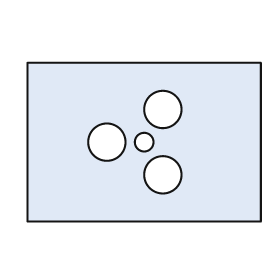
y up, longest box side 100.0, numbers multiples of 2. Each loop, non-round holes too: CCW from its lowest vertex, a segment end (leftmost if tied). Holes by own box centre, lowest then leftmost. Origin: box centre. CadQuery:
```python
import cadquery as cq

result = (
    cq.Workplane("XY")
    .moveTo(-50.0, -34.0)
    .lineTo(50.0, -34.0)
    .lineTo(50.0, 34.0)
    .lineTo(-50.0, 34.0)
    .close()
    .moveTo(8.0, -14.0)
    .circle(8.0)
    .moveTo(-16.0, 0.0)
    .circle(8.0)
    .moveTo(0.0, 0.0)
    .circle(4.0)
    .moveTo(8.0, 14.0)
    .circle(8.0)
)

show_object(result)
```